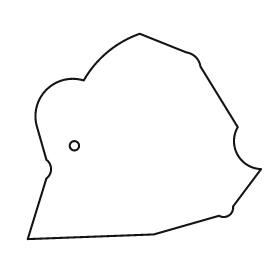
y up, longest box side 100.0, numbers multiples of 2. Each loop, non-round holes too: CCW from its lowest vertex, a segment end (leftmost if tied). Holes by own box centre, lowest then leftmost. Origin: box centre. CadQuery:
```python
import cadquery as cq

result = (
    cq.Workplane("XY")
    .moveTo(-50.0, -44.0)
    .lineTo(4.0, -42.0)
    .lineTo(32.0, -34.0)
    .threePointArc((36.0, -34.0), (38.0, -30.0))
    .lineTo(50.0, -14.0)
    .threePointArc((40.0, -8.0), (40.0, 4.0))
    .lineTo(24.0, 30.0)
    .threePointArc((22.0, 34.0), (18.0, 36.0))
    .lineTo(-2.0, 44.0)
    .threePointArc((-16.0, 36.0), (-26.0, 24.0))
    .threePointArc((-42.0, 20.0), (-46.0, 4.0))
    .lineTo(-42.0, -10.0)
    .threePointArc((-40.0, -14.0), (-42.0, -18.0))
    .close()
    .moveTo(-30.0, -4.0)
    .circle(2.0)
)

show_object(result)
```